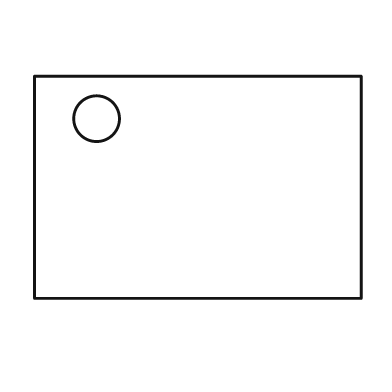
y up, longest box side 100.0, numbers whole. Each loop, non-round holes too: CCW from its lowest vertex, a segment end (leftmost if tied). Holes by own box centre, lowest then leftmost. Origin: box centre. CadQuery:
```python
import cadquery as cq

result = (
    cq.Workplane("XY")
    .moveTo(-50.0, -34.0)
    .lineTo(50.0, -34.0)
    .lineTo(50.0, 34.0)
    .lineTo(-50.0, 34.0)
    .close()
    .moveTo(-31.0, 21.0)
    .circle(7.0)
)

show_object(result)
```